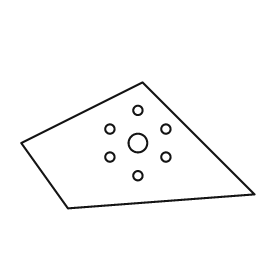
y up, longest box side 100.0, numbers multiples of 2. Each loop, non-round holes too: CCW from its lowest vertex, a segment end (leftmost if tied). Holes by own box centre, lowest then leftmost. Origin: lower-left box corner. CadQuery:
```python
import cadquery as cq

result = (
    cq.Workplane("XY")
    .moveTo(20.0, 0.0)
    .lineTo(100.0, 6.0)
    .lineTo(52.0, 54.0)
    .lineTo(0.0, 28.0)
    .close()
    .moveTo(50.0, 14.0)
    .circle(2.0)
    .moveTo(38.0, 22.0)
    .circle(2.0)
    .moveTo(62.0, 22.0)
    .circle(2.0)
    .moveTo(50.0, 28.0)
    .circle(4.0)
    .moveTo(38.0, 34.0)
    .circle(2.0)
    .moveTo(62.0, 34.0)
    .circle(2.0)
    .moveTo(50.0, 42.0)
    .circle(2.0)
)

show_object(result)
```